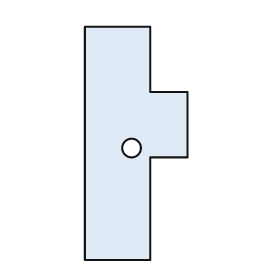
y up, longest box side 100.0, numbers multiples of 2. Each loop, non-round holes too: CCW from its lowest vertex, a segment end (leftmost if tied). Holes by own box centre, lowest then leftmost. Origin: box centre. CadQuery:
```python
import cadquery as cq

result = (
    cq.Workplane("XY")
    .moveTo(-22.0, -50.0)
    .lineTo(6.0, -50.0)
    .lineTo(6.0, -6.0)
    .lineTo(22.0, -6.0)
    .lineTo(22.0, 22.0)
    .lineTo(6.0, 22.0)
    .lineTo(6.0, 50.0)
    .lineTo(-22.0, 50.0)
    .close()
    .moveTo(-2.0, -2.0)
    .circle(4.0)
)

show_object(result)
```